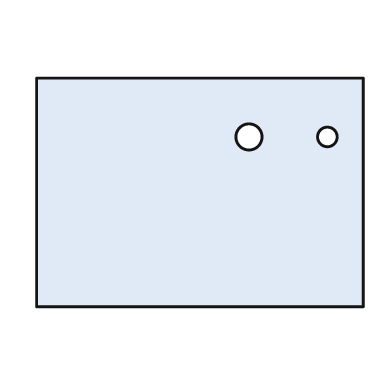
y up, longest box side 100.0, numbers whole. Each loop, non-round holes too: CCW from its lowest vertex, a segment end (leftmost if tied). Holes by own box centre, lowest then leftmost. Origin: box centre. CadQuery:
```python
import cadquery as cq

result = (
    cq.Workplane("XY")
    .moveTo(-50.0, -35.0)
    .lineTo(50.0, -35.0)
    .lineTo(50.0, 35.0)
    .lineTo(-50.0, 35.0)
    .close()
    .moveTo(15.0, 17.0)
    .circle(4.0)
    .moveTo(39.0, 17.0)
    .circle(3.0)
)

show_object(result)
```